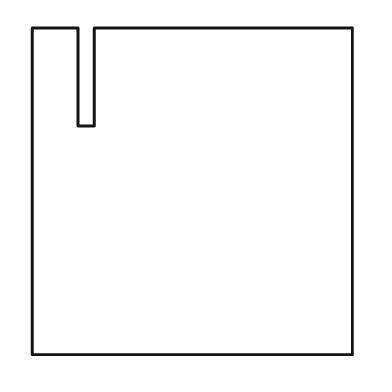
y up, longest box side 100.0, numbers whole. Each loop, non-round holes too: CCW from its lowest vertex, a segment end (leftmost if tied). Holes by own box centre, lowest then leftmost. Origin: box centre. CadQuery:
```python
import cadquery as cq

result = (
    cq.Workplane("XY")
    .moveTo(-49.0, -50.0)
    .lineTo(49.0, -50.0)
    .lineTo(49.0, 50.0)
    .lineTo(-30.0, 50.0)
    .lineTo(-30.0, 20.0)
    .lineTo(-35.0, 20.0)
    .lineTo(-35.0, 50.0)
    .lineTo(-49.0, 50.0)
    .close()
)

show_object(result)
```